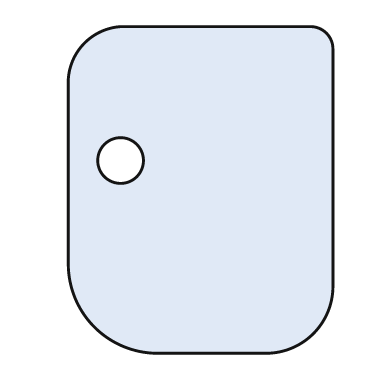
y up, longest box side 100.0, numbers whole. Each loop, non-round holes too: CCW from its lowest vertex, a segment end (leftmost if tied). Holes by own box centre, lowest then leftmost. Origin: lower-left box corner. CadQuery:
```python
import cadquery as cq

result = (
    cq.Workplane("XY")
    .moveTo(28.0, 0.0)
    .lineTo(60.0, 0.0)
    .threePointArc((75.0, 6.0), (81.0, 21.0))
    .lineTo(81.0, 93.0)
    .threePointArc((79.0, 98.0), (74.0, 100.0))
    .lineTo(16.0, 100.0)
    .threePointArc((5.0, 95.0), (0.0, 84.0))
    .lineTo(0.0, 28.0)
    .threePointArc((8.0, 8.0), (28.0, 0.0))
    .close()
    .moveTo(16.0, 59.0)
    .circle(7.0)
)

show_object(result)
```